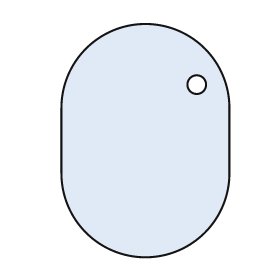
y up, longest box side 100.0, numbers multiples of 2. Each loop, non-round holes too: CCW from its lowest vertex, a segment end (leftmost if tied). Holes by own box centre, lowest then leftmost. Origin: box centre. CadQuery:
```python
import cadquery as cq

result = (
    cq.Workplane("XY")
    .moveTo(-36.0, -14.0)
    .threePointArc((0.0, -50.0), (36.0, -14.0))
    .lineTo(36.0, 14.0)
    .threePointArc((0.0, 50.0), (-36.0, 14.0))
    .close()
    .moveTo(22.0, 24.0)
    .circle(4.0)
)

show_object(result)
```